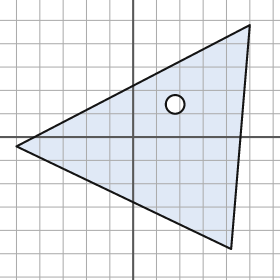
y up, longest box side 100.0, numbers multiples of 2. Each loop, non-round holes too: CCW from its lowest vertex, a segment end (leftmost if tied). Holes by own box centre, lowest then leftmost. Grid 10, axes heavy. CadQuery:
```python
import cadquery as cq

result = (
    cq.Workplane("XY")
    .moveTo(42.0, -48.0)
    .lineTo(50.0, 48.0)
    .lineTo(-50.0, -4.0)
    .close()
    .moveTo(18.0, 14.0)
    .circle(4.0)
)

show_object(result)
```